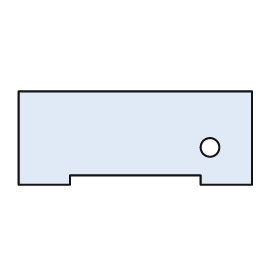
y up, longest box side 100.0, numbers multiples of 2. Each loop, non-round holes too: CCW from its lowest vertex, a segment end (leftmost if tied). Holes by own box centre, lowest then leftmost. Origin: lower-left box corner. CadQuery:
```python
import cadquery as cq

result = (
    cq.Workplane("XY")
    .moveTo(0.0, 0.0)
    .lineTo(22.0, 0.0)
    .lineTo(22.0, 4.0)
    .lineTo(78.0, 4.0)
    .lineTo(78.0, 0.0)
    .lineTo(100.0, 0.0)
    .lineTo(100.0, 40.0)
    .lineTo(0.0, 40.0)
    .close()
    .moveTo(82.0, 16.0)
    .circle(4.0)
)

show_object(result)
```